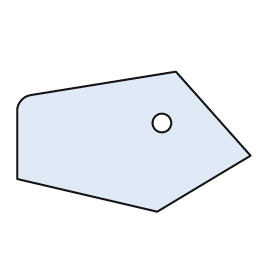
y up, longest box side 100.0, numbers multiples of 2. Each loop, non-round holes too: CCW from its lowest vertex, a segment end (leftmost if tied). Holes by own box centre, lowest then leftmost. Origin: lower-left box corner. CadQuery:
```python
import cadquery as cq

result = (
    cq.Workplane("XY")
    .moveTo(60.0, 0.0)
    .lineTo(100.0, 24.0)
    .lineTo(68.0, 60.0)
    .lineTo(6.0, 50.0)
    .threePointArc((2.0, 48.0), (0.0, 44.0))
    .lineTo(0.0, 14.0)
    .close()
    .moveTo(62.0, 38.0)
    .circle(4.0)
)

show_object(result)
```